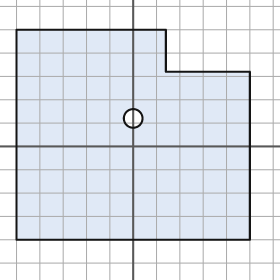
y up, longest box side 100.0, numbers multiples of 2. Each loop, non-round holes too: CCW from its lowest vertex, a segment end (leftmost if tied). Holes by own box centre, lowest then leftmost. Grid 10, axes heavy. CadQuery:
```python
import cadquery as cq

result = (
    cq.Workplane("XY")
    .moveTo(-50.0, -40.0)
    .lineTo(50.0, -40.0)
    .lineTo(50.0, 32.0)
    .lineTo(14.0, 32.0)
    .lineTo(14.0, 50.0)
    .lineTo(-50.0, 50.0)
    .close()
    .moveTo(0.0, 12.0)
    .circle(4.0)
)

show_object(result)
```